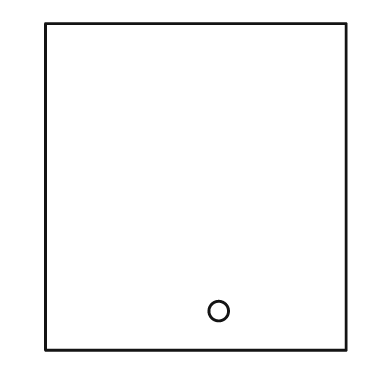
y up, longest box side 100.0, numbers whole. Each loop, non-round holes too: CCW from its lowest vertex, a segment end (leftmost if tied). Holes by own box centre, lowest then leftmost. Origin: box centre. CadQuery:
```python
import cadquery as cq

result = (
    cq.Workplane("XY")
    .moveTo(-46.0, -50.0)
    .lineTo(46.0, -50.0)
    .lineTo(46.0, 50.0)
    .lineTo(-46.0, 50.0)
    .close()
    .moveTo(7.0, -38.0)
    .circle(3.0)
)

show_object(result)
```